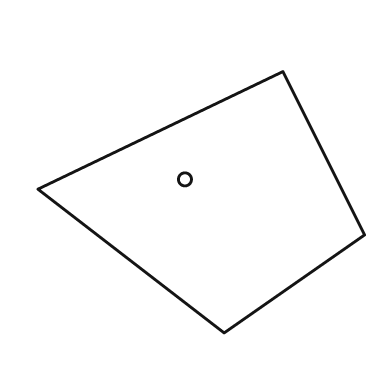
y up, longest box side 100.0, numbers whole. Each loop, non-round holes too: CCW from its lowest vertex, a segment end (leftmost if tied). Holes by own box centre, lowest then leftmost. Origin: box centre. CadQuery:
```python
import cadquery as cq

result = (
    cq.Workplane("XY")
    .moveTo(7.0, -40.0)
    .lineTo(50.0, -10.0)
    .lineTo(25.0, 40.0)
    .lineTo(-50.0, 4.0)
    .close()
    .moveTo(-5.0, 7.0)
    .circle(2.0)
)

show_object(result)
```